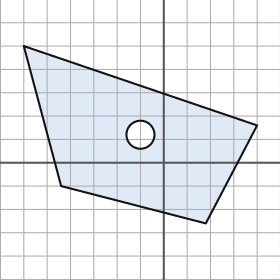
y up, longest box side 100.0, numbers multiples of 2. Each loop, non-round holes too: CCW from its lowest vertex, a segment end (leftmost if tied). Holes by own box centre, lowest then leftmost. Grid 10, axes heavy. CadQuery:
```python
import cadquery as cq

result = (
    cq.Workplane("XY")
    .moveTo(18.0, -26.0)
    .lineTo(40.0, 16.0)
    .lineTo(-60.0, 50.0)
    .lineTo(-44.0, -10.0)
    .close()
    .moveTo(-10.0, 12.0)
    .circle(6.0)
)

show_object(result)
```